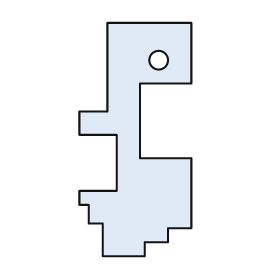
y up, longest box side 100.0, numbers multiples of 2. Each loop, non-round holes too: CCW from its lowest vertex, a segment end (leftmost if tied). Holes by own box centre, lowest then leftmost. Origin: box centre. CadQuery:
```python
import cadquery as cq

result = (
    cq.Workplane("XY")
    .moveTo(-14.0, -50.0)
    .lineTo(4.0, -50.0)
    .lineTo(4.0, -44.0)
    .lineTo(14.0, -44.0)
    .lineTo(14.0, -38.0)
    .lineTo(24.0, -38.0)
    .lineTo(24.0, -8.0)
    .lineTo(2.0, -8.0)
    .lineTo(2.0, 24.0)
    .lineTo(24.0, 24.0)
    .lineTo(24.0, 50.0)
    .lineTo(-12.0, 50.0)
    .lineTo(-12.0, 12.0)
    .lineTo(-24.0, 12.0)
    .lineTo(-24.0, 2.0)
    .lineTo(-8.0, 2.0)
    .lineTo(-8.0, -22.0)
    .lineTo(-24.0, -22.0)
    .lineTo(-24.0, -28.0)
    .lineTo(-20.0, -28.0)
    .lineTo(-20.0, -36.0)
    .lineTo(-14.0, -36.0)
    .close()
    .moveTo(10.0, 34.0)
    .circle(4.0)
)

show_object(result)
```